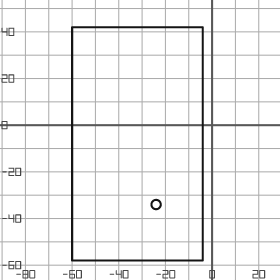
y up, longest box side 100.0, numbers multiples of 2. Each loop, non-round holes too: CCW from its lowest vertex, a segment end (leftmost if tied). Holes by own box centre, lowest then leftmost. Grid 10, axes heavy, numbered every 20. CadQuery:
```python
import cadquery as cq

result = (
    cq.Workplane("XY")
    .moveTo(-60.0, -58.0)
    .lineTo(-4.0, -58.0)
    .lineTo(-4.0, 42.0)
    .lineTo(-60.0, 42.0)
    .close()
    .moveTo(-24.0, -34.0)
    .circle(2.0)
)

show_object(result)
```